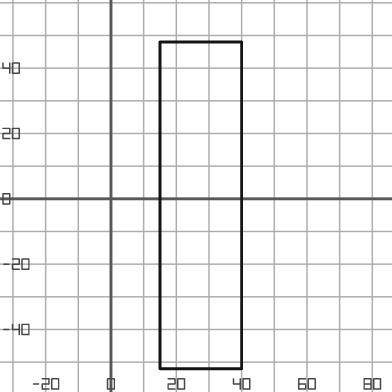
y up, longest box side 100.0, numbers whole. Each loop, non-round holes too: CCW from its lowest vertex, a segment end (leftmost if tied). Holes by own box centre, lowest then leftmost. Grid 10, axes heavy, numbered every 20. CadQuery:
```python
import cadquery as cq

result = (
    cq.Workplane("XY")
    .moveTo(15.0, -52.0)
    .lineTo(40.0, -52.0)
    .lineTo(40.0, 48.0)
    .lineTo(15.0, 48.0)
    .close()
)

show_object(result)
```